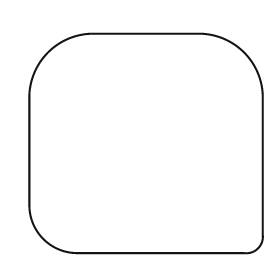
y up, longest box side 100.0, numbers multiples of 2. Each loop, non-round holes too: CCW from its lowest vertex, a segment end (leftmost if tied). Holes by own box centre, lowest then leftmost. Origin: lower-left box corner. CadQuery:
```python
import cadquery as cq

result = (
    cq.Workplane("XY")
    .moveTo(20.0, 0.0)
    .lineTo(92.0, 0.0)
    .threePointArc((98.0, 2.0), (100.0, 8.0))
    .lineTo(100.0, 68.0)
    .threePointArc((92.0, 86.0), (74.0, 94.0))
    .lineTo(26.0, 94.0)
    .threePointArc((8.0, 86.0), (0.0, 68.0))
    .lineTo(0.0, 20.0)
    .threePointArc((6.0, 6.0), (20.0, 0.0))
    .close()
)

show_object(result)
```